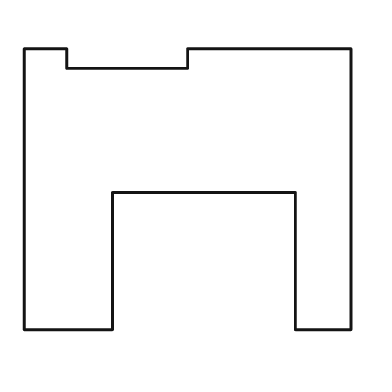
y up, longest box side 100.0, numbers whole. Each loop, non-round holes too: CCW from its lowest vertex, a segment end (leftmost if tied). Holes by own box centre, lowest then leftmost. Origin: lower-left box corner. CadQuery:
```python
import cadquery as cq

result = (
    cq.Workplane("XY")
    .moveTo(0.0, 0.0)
    .lineTo(27.0, 0.0)
    .lineTo(27.0, 42.0)
    .lineTo(83.0, 42.0)
    .lineTo(83.0, 0.0)
    .lineTo(100.0, 0.0)
    .lineTo(100.0, 86.0)
    .lineTo(50.0, 86.0)
    .lineTo(50.0, 80.0)
    .lineTo(13.0, 80.0)
    .lineTo(13.0, 86.0)
    .lineTo(0.0, 86.0)
    .close()
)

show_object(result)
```